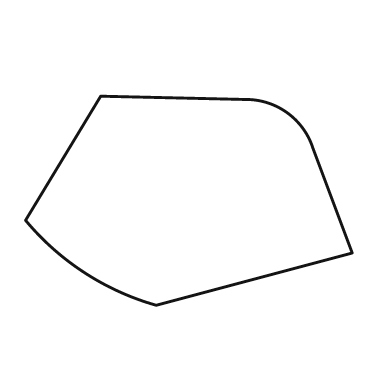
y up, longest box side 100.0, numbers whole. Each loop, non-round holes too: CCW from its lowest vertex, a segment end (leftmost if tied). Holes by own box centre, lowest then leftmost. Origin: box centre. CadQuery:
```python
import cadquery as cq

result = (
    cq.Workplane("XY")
    .moveTo(-10.0, -32.0)
    .lineTo(50.0, -16.0)
    .lineTo(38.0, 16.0)
    .threePointArc((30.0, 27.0), (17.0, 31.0))
    .lineTo(-27.0, 32.0)
    .lineTo(-50.0, -6.0)
    .threePointArc((-32.0, -22.0), (-10.0, -32.0))
    .close()
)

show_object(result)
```